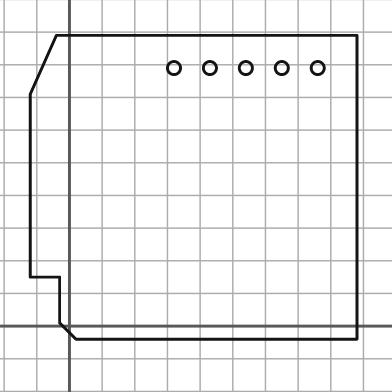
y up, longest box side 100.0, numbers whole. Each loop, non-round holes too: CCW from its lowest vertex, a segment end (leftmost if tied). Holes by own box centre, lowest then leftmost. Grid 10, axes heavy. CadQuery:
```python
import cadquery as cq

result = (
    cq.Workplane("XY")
    .moveTo(2.0, -4.0)
    .lineTo(88.0, -4.0)
    .lineTo(88.0, 89.0)
    .lineTo(-4.0, 89.0)
    .lineTo(-12.0, 71.0)
    .lineTo(-12.0, 15.0)
    .lineTo(-3.0, 15.0)
    .lineTo(-3.0, 1.0)
    .close()
    .moveTo(32.0, 79.0)
    .circle(2.0)
    .moveTo(43.0, 79.0)
    .circle(2.0)
    .moveTo(54.0, 79.0)
    .circle(2.0)
    .moveTo(65.0, 79.0)
    .circle(2.0)
    .moveTo(76.0, 79.0)
    .circle(2.0)
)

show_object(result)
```